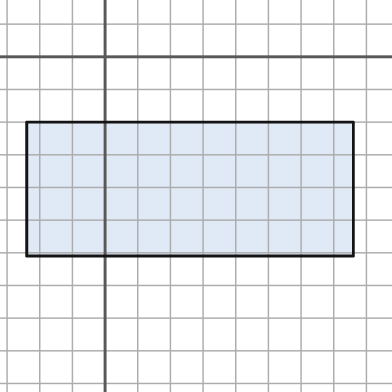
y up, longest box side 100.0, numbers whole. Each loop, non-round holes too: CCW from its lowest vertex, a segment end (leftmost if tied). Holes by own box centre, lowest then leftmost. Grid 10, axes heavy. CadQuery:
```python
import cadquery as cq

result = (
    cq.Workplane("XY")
    .moveTo(-24.0, -61.0)
    .lineTo(76.0, -61.0)
    .lineTo(76.0, -20.0)
    .lineTo(-24.0, -20.0)
    .close()
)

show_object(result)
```